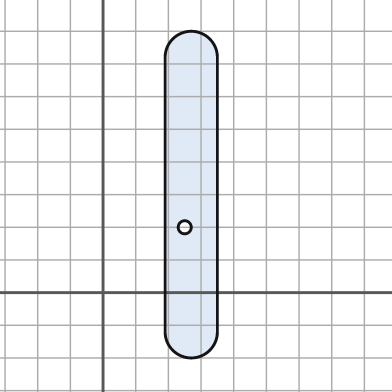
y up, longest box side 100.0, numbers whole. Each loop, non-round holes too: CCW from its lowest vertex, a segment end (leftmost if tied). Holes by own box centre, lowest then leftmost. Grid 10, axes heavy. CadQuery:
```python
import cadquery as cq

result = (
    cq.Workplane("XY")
    .moveTo(19.0, -12.0)
    .threePointArc((27.0, -20.0), (35.0, -12.0))
    .lineTo(35.0, 72.0)
    .threePointArc((27.0, 80.0), (19.0, 72.0))
    .close()
    .moveTo(25.0, 20.0)
    .circle(2.0)
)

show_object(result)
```